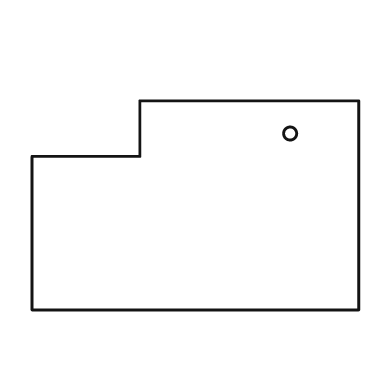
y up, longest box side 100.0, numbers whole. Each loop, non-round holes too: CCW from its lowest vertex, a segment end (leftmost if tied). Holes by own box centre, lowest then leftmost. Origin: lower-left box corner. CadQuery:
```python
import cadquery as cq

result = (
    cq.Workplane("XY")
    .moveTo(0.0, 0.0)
    .lineTo(100.0, 0.0)
    .lineTo(100.0, 64.0)
    .lineTo(33.0, 64.0)
    .lineTo(33.0, 47.0)
    .lineTo(0.0, 47.0)
    .close()
    .moveTo(79.0, 54.0)
    .circle(2.0)
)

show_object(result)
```